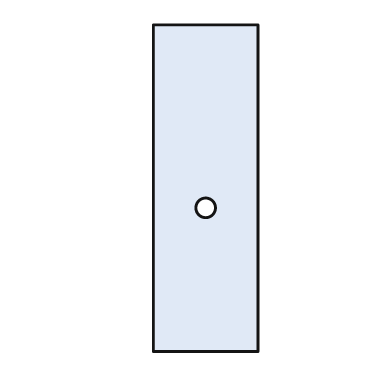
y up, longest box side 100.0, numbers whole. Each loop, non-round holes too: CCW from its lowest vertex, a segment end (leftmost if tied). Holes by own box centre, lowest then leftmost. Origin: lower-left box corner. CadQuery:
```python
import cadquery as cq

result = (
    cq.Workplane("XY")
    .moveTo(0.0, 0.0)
    .lineTo(32.0, 0.0)
    .lineTo(32.0, 100.0)
    .lineTo(0.0, 100.0)
    .close()
    .moveTo(16.0, 44.0)
    .circle(3.0)
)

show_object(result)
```